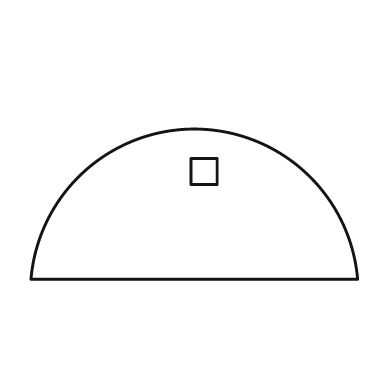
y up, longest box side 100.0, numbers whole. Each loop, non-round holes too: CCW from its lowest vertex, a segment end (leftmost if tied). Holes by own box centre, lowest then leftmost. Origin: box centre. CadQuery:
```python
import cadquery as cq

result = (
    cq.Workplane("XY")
    .moveTo(-50.0, -23.0)
    .lineTo(50.0, -23.0)
    .threePointArc((0.0, 23.0), (-50.0, -23.0))
    .close()
    .moveTo(-1.0, 6.0)
    .lineTo(7.0, 6.0)
    .lineTo(7.0, 14.0)
    .lineTo(-1.0, 14.0)
    .close()
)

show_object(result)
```